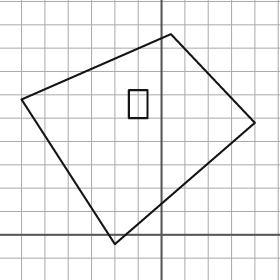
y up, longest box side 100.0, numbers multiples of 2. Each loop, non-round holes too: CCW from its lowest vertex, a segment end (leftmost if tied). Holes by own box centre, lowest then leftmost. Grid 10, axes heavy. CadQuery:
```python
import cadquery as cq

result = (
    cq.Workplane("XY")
    .moveTo(-20.0, -4.0)
    .lineTo(40.0, 48.0)
    .lineTo(4.0, 86.0)
    .lineTo(-60.0, 58.0)
    .close()
    .moveTo(-14.0, 50.0)
    .lineTo(-6.0, 50.0)
    .lineTo(-6.0, 62.0)
    .lineTo(-14.0, 62.0)
    .close()
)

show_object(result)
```